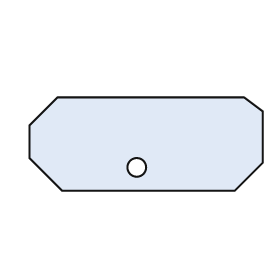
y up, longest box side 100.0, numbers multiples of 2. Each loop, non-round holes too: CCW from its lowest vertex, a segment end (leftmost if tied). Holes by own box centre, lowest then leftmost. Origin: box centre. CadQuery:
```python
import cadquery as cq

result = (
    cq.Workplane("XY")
    .moveTo(-36.0, -20.0)
    .lineTo(38.0, -20.0)
    .lineTo(50.0, -8.0)
    .lineTo(50.0, 14.0)
    .lineTo(42.0, 20.0)
    .lineTo(-38.0, 20.0)
    .lineTo(-50.0, 8.0)
    .lineTo(-50.0, -6.0)
    .close()
    .moveTo(-4.0, -10.0)
    .circle(4.0)
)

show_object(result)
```